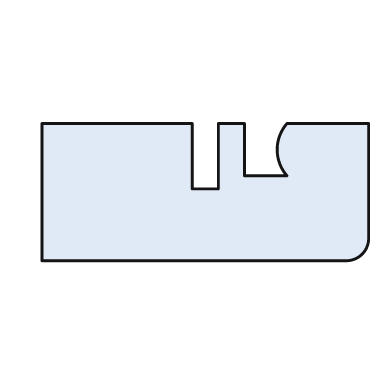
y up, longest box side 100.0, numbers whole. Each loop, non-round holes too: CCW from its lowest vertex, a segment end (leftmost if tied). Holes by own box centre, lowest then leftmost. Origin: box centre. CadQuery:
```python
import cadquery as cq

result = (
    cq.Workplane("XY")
    .moveTo(-50.0, -21.0)
    .lineTo(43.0, -21.0)
    .threePointArc((48.0, -19.0), (50.0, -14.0))
    .lineTo(50.0, 21.0)
    .lineTo(25.0, 21.0)
    .threePointArc((22.0, 13.0), (25.0, 5.0))
    .lineTo(12.0, 5.0)
    .lineTo(12.0, 21.0)
    .lineTo(4.0, 21.0)
    .lineTo(4.0, 1.0)
    .lineTo(-4.0, 1.0)
    .lineTo(-4.0, 21.0)
    .lineTo(-50.0, 21.0)
    .close()
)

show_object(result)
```